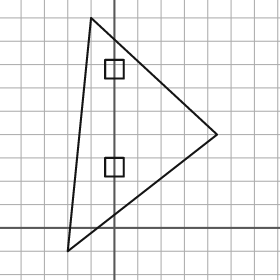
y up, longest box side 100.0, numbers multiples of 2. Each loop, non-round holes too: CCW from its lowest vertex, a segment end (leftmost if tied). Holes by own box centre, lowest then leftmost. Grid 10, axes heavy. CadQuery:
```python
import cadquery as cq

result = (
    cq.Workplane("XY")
    .moveTo(-20.0, -10.0)
    .lineTo(44.0, 40.0)
    .lineTo(-10.0, 90.0)
    .close()
    .moveTo(-4.0, 22.0)
    .lineTo(4.0, 22.0)
    .lineTo(4.0, 30.0)
    .lineTo(-4.0, 30.0)
    .close()
    .moveTo(-4.0, 64.0)
    .lineTo(4.0, 64.0)
    .lineTo(4.0, 72.0)
    .lineTo(-4.0, 72.0)
    .close()
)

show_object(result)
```